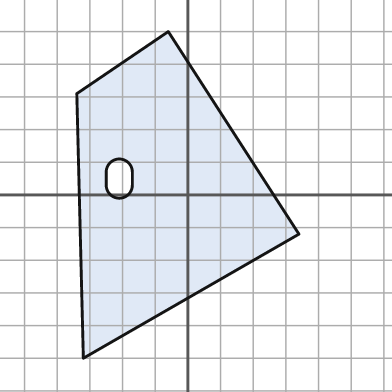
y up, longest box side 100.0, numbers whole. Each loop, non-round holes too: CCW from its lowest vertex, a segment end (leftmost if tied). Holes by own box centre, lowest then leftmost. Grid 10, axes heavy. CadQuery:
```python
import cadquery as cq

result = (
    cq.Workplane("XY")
    .moveTo(-32.0, -50.0)
    .lineTo(34.0, -12.0)
    .lineTo(-6.0, 50.0)
    .lineTo(-34.0, 31.0)
    .close()
    .moveTo(-25.0, 3.0)
    .threePointArc((-21.0, -1.0), (-17.0, 3.0))
    .lineTo(-17.0, 7.0)
    .threePointArc((-21.0, 11.0), (-25.0, 7.0))
    .close()
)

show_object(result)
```